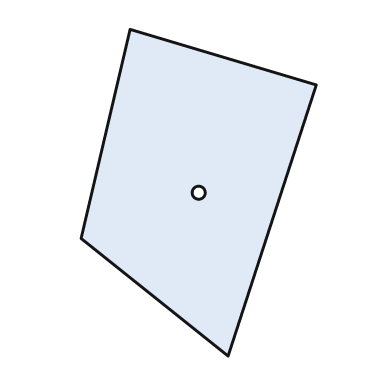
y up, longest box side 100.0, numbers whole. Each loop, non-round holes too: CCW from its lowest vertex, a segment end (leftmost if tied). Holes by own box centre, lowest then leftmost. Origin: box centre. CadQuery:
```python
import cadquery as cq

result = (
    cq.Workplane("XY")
    .moveTo(9.0, -50.0)
    .lineTo(36.0, 33.0)
    .lineTo(-21.0, 50.0)
    .lineTo(-36.0, -14.0)
    .close()
    .moveTo(0.0, 0.0)
    .circle(2.0)
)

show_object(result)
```